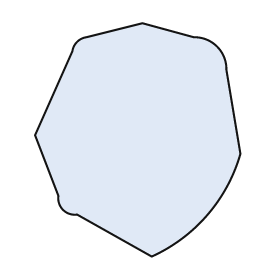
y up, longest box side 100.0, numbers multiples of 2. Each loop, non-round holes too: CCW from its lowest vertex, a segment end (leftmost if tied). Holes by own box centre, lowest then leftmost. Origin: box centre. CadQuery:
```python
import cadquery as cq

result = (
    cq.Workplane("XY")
    .moveTo(6.0, -50.0)
    .threePointArc((30.0, -32.0), (44.0, -6.0))
    .lineTo(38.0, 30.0)
    .threePointArc((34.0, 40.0), (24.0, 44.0))
    .lineTo(2.0, 50.0)
    .lineTo(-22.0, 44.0)
    .threePointArc((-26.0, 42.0), (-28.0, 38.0))
    .lineTo(-44.0, 2.0)
    .lineTo(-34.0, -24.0)
    .threePointArc((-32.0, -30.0), (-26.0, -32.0))
    .close()
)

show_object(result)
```